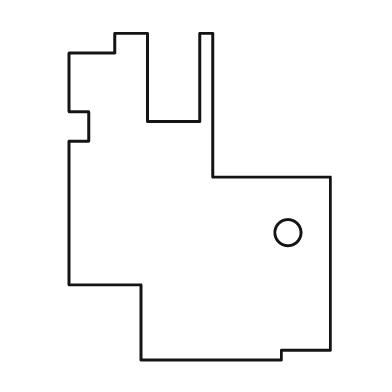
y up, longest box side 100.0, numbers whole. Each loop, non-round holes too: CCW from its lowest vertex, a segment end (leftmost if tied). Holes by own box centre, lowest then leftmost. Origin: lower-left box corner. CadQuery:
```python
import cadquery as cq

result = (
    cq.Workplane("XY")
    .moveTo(22.0, 0.0)
    .lineTo(65.0, 0.0)
    .lineTo(65.0, 3.0)
    .lineTo(80.0, 3.0)
    .lineTo(80.0, 56.0)
    .lineTo(44.0, 56.0)
    .lineTo(44.0, 100.0)
    .lineTo(40.0, 100.0)
    .lineTo(40.0, 73.0)
    .lineTo(24.0, 73.0)
    .lineTo(24.0, 100.0)
    .lineTo(14.0, 100.0)
    .lineTo(14.0, 94.0)
    .lineTo(0.0, 94.0)
    .lineTo(0.0, 76.0)
    .lineTo(6.0, 76.0)
    .lineTo(6.0, 67.0)
    .lineTo(0.0, 67.0)
    .lineTo(0.0, 23.0)
    .lineTo(22.0, 23.0)
    .close()
    .moveTo(67.0, 39.0)
    .circle(4.0)
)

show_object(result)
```